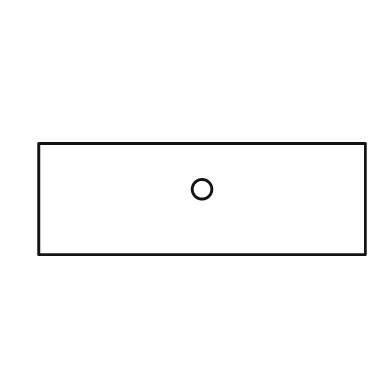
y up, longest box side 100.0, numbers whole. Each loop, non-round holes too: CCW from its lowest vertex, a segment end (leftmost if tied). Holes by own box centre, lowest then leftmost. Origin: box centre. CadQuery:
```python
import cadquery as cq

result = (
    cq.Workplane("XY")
    .moveTo(-50.0, -17.0)
    .lineTo(50.0, -17.0)
    .lineTo(50.0, 17.0)
    .lineTo(-50.0, 17.0)
    .close()
    .moveTo(0.0, 3.0)
    .circle(3.0)
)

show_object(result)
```